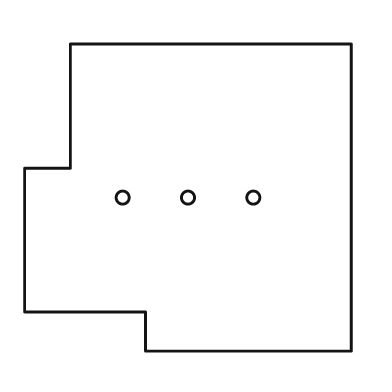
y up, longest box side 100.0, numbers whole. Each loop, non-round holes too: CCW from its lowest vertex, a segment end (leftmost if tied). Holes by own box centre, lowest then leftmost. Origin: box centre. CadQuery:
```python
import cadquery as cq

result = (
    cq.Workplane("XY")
    .moveTo(-13.0, -47.0)
    .lineTo(50.0, -47.0)
    .lineTo(50.0, 47.0)
    .lineTo(-36.0, 47.0)
    .lineTo(-36.0, 9.0)
    .lineTo(-50.0, 9.0)
    .lineTo(-50.0, -35.0)
    .lineTo(-13.0, -35.0)
    .close()
    .moveTo(-20.0, 0.0)
    .circle(2.0)
    .moveTo(0.0, 0.0)
    .circle(2.0)
    .moveTo(20.0, 0.0)
    .circle(2.0)
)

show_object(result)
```